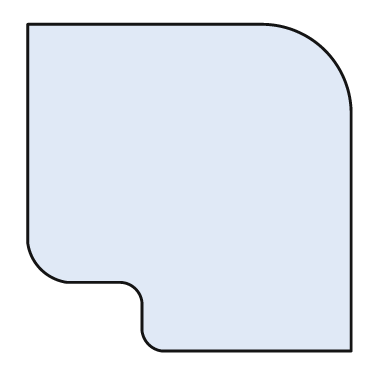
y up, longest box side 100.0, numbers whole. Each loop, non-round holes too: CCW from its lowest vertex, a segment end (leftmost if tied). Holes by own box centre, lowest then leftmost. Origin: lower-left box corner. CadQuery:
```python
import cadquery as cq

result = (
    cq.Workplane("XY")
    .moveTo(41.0, 0.0)
    .lineTo(99.0, 0.0)
    .lineTo(99.0, 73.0)
    .threePointArc((91.0, 92.0), (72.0, 100.0))
    .lineTo(0.0, 100.0)
    .lineTo(0.0, 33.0)
    .threePointArc((4.0, 25.0), (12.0, 21.0))
    .lineTo(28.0, 21.0)
    .threePointArc((33.0, 19.0), (35.0, 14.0))
    .lineTo(35.0, 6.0)
    .threePointArc((37.0, 2.0), (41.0, 0.0))
    .close()
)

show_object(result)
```